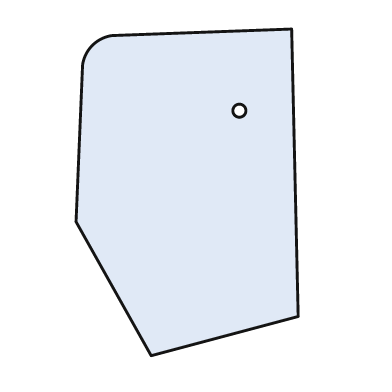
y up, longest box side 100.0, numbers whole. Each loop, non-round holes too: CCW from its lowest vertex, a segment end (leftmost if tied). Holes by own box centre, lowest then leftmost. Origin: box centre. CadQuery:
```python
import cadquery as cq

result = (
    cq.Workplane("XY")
    .moveTo(-11.0, -50.0)
    .lineTo(34.0, -38.0)
    .lineTo(32.0, 50.0)
    .lineTo(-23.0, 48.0)
    .threePointArc((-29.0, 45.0), (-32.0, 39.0))
    .lineTo(-34.0, -9.0)
    .close()
    .moveTo(16.0, 25.0)
    .circle(2.0)
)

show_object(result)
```